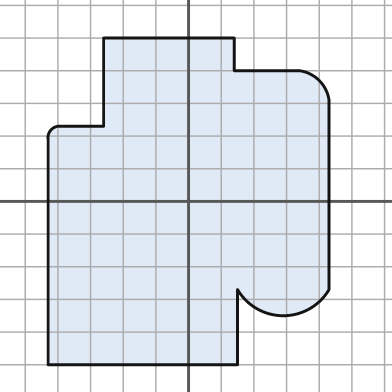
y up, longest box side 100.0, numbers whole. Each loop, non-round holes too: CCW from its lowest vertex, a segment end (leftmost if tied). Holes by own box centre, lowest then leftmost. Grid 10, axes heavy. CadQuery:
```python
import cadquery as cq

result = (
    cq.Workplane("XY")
    .moveTo(-43.0, -50.0)
    .lineTo(15.0, -50.0)
    .lineTo(15.0, -27.0)
    .threePointArc((29.0, -35.0), (43.0, -27.0))
    .lineTo(43.0, 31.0)
    .threePointArc((40.0, 37.0), (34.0, 40.0))
    .lineTo(14.0, 40.0)
    .lineTo(14.0, 50.0)
    .lineTo(-26.0, 50.0)
    .lineTo(-26.0, 23.0)
    .lineTo(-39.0, 23.0)
    .threePointArc((-42.0, 22.0), (-43.0, 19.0))
    .close()
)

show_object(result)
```